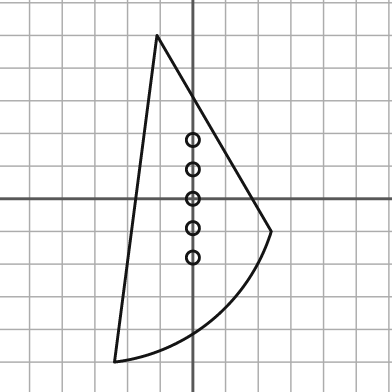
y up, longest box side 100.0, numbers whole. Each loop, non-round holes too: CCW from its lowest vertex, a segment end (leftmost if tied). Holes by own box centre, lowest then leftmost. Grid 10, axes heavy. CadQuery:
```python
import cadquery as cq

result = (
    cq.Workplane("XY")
    .moveTo(-24.0, -50.0)
    .threePointArc((6.0, -37.0), (24.0, -10.0))
    .lineTo(-11.0, 50.0)
    .close()
    .moveTo(0.0, -18.0)
    .circle(2.0)
    .moveTo(0.0, -9.0)
    .circle(2.0)
    .moveTo(0.0, 0.0)
    .circle(2.0)
    .moveTo(0.0, 9.0)
    .circle(2.0)
    .moveTo(0.0, 18.0)
    .circle(2.0)
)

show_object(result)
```